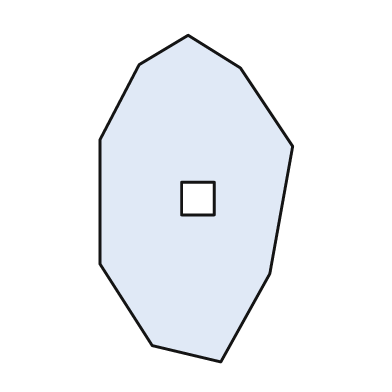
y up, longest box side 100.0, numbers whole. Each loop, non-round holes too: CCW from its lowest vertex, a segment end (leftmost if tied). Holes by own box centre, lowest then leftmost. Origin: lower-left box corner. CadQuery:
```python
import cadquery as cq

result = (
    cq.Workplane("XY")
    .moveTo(37.0, 0.0)
    .lineTo(52.0, 27.0)
    .lineTo(59.0, 66.0)
    .lineTo(43.0, 90.0)
    .lineTo(27.0, 100.0)
    .lineTo(12.0, 91.0)
    .lineTo(0.0, 68.0)
    .lineTo(0.0, 30.0)
    .lineTo(16.0, 5.0)
    .close()
    .moveTo(25.0, 45.0)
    .lineTo(35.0, 45.0)
    .lineTo(35.0, 55.0)
    .lineTo(25.0, 55.0)
    .close()
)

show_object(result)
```